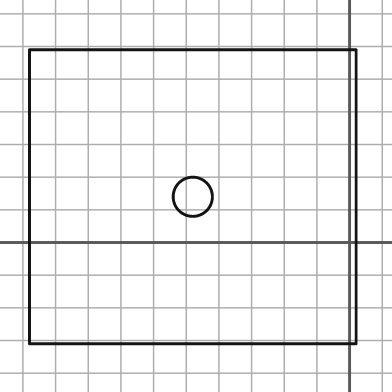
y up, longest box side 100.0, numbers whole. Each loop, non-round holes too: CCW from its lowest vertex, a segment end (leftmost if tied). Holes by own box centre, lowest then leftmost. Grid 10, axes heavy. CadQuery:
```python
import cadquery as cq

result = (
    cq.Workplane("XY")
    .moveTo(-98.0, -31.0)
    .lineTo(2.0, -31.0)
    .lineTo(2.0, 59.0)
    .lineTo(-98.0, 59.0)
    .close()
    .moveTo(-48.0, 14.0)
    .circle(6.0)
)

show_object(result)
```